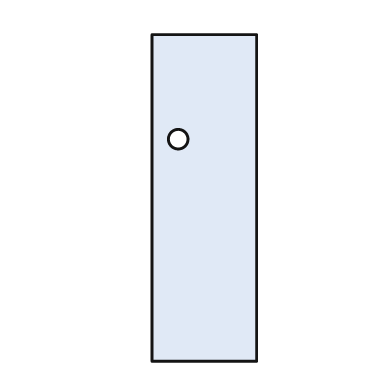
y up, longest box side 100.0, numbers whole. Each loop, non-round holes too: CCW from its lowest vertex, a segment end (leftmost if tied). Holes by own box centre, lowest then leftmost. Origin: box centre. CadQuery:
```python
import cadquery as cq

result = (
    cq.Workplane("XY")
    .moveTo(-16.0, -50.0)
    .lineTo(16.0, -50.0)
    .lineTo(16.0, 50.0)
    .lineTo(-16.0, 50.0)
    .close()
    .moveTo(-8.0, 18.0)
    .circle(3.0)
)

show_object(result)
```